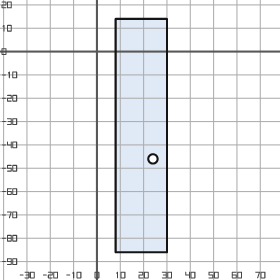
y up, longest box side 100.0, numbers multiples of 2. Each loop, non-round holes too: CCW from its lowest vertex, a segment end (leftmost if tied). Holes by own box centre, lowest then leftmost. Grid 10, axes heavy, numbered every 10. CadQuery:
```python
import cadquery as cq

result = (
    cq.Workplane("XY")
    .moveTo(8.0, -86.0)
    .lineTo(30.0, -86.0)
    .lineTo(30.0, 14.0)
    .lineTo(8.0, 14.0)
    .close()
    .moveTo(24.0, -46.0)
    .circle(2.0)
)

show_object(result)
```